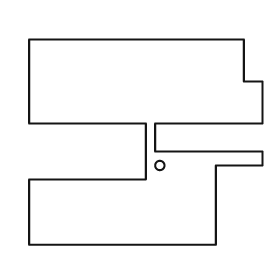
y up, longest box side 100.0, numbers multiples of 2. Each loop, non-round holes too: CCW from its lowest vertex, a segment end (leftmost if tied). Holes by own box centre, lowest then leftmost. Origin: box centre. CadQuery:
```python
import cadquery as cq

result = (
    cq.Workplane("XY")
    .moveTo(-50.0, -44.0)
    .lineTo(30.0, -44.0)
    .lineTo(30.0, -10.0)
    .lineTo(50.0, -10.0)
    .lineTo(50.0, -4.0)
    .lineTo(4.0, -4.0)
    .lineTo(4.0, 8.0)
    .lineTo(50.0, 8.0)
    .lineTo(50.0, 26.0)
    .lineTo(42.0, 26.0)
    .lineTo(42.0, 44.0)
    .lineTo(-50.0, 44.0)
    .lineTo(-50.0, 8.0)
    .lineTo(0.0, 8.0)
    .lineTo(0.0, -16.0)
    .lineTo(-50.0, -16.0)
    .close()
    .moveTo(6.0, -10.0)
    .circle(2.0)
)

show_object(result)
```